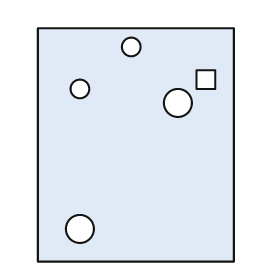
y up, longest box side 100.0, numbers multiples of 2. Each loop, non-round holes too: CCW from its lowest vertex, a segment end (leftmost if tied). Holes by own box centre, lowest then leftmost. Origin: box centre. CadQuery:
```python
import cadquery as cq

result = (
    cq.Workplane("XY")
    .moveTo(-42.0, -50.0)
    .lineTo(42.0, -50.0)
    .lineTo(42.0, 50.0)
    .lineTo(-42.0, 50.0)
    .close()
    .moveTo(-24.0, -36.0)
    .circle(6.0)
    .moveTo(18.0, 18.0)
    .circle(6.0)
    .moveTo(-24.0, 24.0)
    .circle(4.0)
    .moveTo(26.0, 24.0)
    .lineTo(34.0, 24.0)
    .lineTo(34.0, 32.0)
    .lineTo(26.0, 32.0)
    .close()
    .moveTo(-2.0, 42.0)
    .circle(4.0)
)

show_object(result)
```